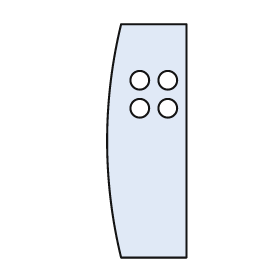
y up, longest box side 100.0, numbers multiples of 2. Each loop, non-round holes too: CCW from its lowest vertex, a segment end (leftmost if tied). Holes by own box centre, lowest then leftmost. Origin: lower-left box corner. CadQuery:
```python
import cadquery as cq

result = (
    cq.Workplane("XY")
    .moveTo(6.0, 0.0)
    .lineTo(34.0, 0.0)
    .lineTo(34.0, 100.0)
    .lineTo(6.0, 100.0)
    .threePointArc((0.0, 50.0), (6.0, 0.0))
    .close()
    .moveTo(14.0, 64.0)
    .circle(4.0)
    .moveTo(26.0, 64.0)
    .circle(4.0)
    .moveTo(14.0, 76.0)
    .circle(4.0)
    .moveTo(26.0, 76.0)
    .circle(4.0)
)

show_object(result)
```